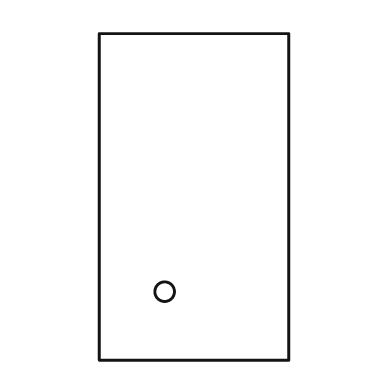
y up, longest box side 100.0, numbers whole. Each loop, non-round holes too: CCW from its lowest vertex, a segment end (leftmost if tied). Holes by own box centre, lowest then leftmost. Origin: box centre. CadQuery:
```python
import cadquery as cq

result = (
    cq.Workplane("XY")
    .moveTo(-29.0, -50.0)
    .lineTo(29.0, -50.0)
    .lineTo(29.0, 50.0)
    .lineTo(-29.0, 50.0)
    .close()
    .moveTo(-9.0, -29.0)
    .circle(3.0)
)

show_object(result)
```